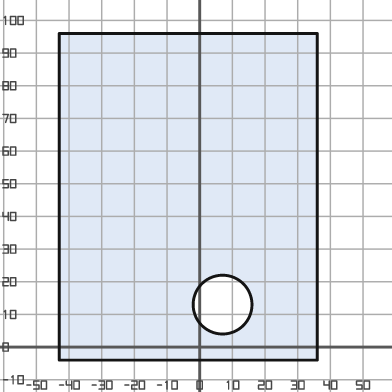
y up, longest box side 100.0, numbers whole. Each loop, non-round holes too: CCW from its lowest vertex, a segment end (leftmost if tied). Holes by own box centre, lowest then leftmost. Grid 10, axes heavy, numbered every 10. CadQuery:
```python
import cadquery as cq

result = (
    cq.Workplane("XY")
    .moveTo(-43.0, -4.0)
    .lineTo(36.0, -4.0)
    .lineTo(36.0, 96.0)
    .lineTo(-43.0, 96.0)
    .close()
    .moveTo(7.0, 13.0)
    .circle(9.0)
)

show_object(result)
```